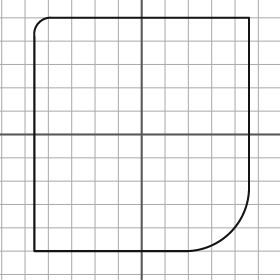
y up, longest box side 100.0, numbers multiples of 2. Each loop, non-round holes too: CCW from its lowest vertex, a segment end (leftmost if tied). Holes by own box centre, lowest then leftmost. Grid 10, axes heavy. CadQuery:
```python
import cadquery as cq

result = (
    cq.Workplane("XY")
    .moveTo(-46.0, -50.0)
    .lineTo(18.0, -50.0)
    .threePointArc((38.0, -42.0), (46.0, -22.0))
    .lineTo(46.0, 50.0)
    .lineTo(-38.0, 50.0)
    .threePointArc((-44.0, 48.0), (-46.0, 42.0))
    .close()
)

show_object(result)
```